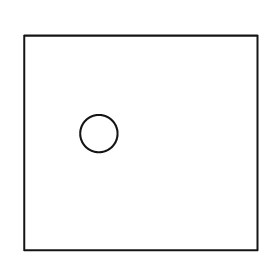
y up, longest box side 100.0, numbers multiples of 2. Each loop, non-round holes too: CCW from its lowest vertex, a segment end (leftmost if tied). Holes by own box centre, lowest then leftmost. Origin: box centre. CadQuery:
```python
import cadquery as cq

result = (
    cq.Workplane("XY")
    .moveTo(-50.0, -46.0)
    .lineTo(50.0, -46.0)
    .lineTo(50.0, 46.0)
    .lineTo(-50.0, 46.0)
    .close()
    .moveTo(-18.0, 4.0)
    .circle(8.0)
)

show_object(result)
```